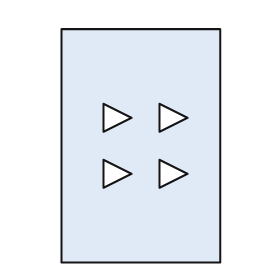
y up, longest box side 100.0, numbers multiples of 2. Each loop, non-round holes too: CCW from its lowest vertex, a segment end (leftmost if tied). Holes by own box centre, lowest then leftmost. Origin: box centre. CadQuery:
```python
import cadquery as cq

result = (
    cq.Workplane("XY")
    .moveTo(-34.0, -50.0)
    .lineTo(34.0, -50.0)
    .lineTo(34.0, 50.0)
    .lineTo(-34.0, 50.0)
    .close()
    .moveTo(-16.0, -18.0)
    .lineTo(-4.0, -12.0)
    .lineTo(-16.0, -6.0)
    .close()
    .moveTo(8.0, -18.0)
    .lineTo(20.0, -12.0)
    .lineTo(8.0, -6.0)
    .close()
    .moveTo(-16.0, 6.0)
    .lineTo(-4.0, 12.0)
    .lineTo(-16.0, 18.0)
    .close()
    .moveTo(8.0, 6.0)
    .lineTo(20.0, 12.0)
    .lineTo(8.0, 18.0)
    .close()
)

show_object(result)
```